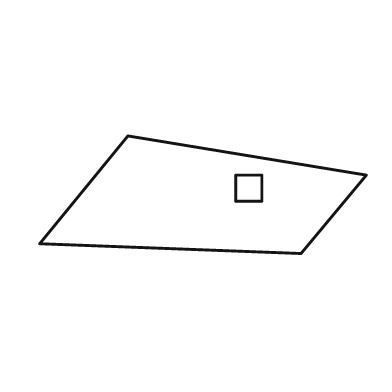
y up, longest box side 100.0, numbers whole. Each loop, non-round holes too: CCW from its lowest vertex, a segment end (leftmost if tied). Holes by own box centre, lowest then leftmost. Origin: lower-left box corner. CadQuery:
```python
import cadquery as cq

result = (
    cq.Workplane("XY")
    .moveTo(80.0, 0.0)
    .lineTo(100.0, 24.0)
    .lineTo(27.0, 36.0)
    .lineTo(0.0, 3.0)
    .close()
    .moveTo(60.0, 16.0)
    .lineTo(68.0, 16.0)
    .lineTo(68.0, 24.0)
    .lineTo(60.0, 24.0)
    .close()
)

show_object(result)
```